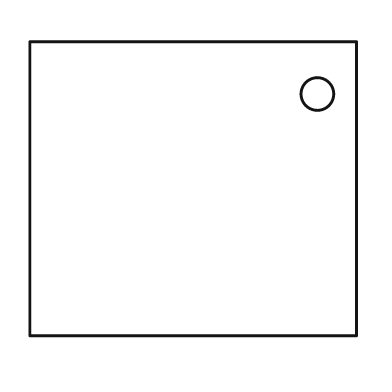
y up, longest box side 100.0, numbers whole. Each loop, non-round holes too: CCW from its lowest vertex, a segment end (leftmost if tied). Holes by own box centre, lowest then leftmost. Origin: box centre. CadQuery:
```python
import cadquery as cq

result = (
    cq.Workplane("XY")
    .moveTo(-50.0, -45.0)
    .lineTo(50.0, -45.0)
    .lineTo(50.0, 45.0)
    .lineTo(-50.0, 45.0)
    .close()
    .moveTo(38.0, 29.0)
    .circle(5.0)
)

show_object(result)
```